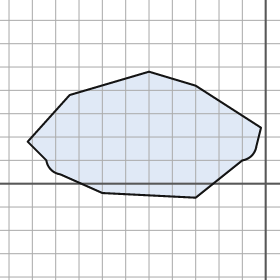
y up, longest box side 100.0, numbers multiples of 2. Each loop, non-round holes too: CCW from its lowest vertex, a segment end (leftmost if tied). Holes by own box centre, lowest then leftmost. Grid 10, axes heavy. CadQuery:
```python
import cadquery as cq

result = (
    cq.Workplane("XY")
    .moveTo(-30.0, -6.0)
    .lineTo(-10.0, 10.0)
    .threePointArc((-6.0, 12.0), (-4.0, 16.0))
    .lineTo(-2.0, 24.0)
    .lineTo(-30.0, 42.0)
    .lineTo(-50.0, 48.0)
    .lineTo(-84.0, 38.0)
    .lineTo(-102.0, 18.0)
    .lineTo(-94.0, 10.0)
    .threePointArc((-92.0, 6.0), (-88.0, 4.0))
    .lineTo(-70.0, -4.0)
    .close()
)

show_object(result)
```